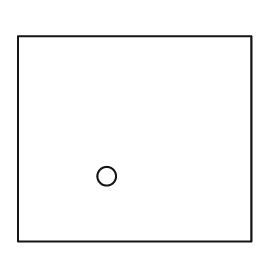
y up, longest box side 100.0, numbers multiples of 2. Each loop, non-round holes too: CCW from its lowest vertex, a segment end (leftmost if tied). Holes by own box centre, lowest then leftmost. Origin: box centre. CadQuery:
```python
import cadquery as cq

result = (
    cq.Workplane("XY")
    .moveTo(-50.0, -44.0)
    .lineTo(50.0, -44.0)
    .lineTo(50.0, 44.0)
    .lineTo(-50.0, 44.0)
    .close()
    .moveTo(-12.0, -16.0)
    .circle(4.0)
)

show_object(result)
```